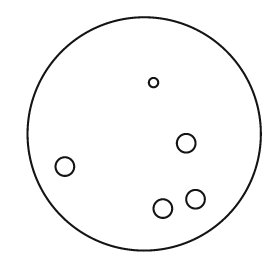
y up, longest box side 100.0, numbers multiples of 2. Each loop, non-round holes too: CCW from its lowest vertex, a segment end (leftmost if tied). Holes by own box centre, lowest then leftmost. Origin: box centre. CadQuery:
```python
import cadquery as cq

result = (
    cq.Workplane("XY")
    .moveTo(0.0, 0.0)
    .circle(50.0)
    .moveTo(8.0, -32.0)
    .circle(4.0)
    .moveTo(22.0, -28.0)
    .circle(4.0)
    .moveTo(-34.0, -14.0)
    .circle(4.0)
    .moveTo(18.0, -4.0)
    .circle(4.0)
    .moveTo(4.0, 22.0)
    .circle(2.0)
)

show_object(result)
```